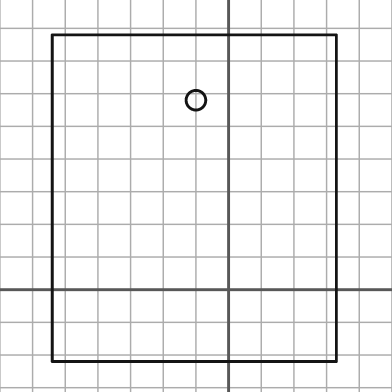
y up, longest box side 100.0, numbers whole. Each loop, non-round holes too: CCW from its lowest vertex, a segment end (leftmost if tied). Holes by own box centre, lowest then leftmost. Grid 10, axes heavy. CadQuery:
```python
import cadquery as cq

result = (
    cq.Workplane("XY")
    .moveTo(-54.0, -22.0)
    .lineTo(33.0, -22.0)
    .lineTo(33.0, 78.0)
    .lineTo(-54.0, 78.0)
    .close()
    .moveTo(-10.0, 58.0)
    .circle(3.0)
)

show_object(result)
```